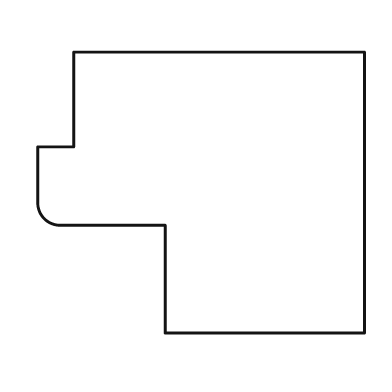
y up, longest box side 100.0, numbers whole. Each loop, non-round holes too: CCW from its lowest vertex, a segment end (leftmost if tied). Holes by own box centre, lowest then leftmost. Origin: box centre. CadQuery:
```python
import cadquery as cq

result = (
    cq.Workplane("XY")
    .moveTo(-11.0, -43.0)
    .lineTo(50.0, -43.0)
    .lineTo(50.0, 43.0)
    .lineTo(-39.0, 43.0)
    .lineTo(-39.0, 14.0)
    .lineTo(-50.0, 14.0)
    .lineTo(-50.0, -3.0)
    .threePointArc((-48.0, -8.0), (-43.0, -10.0))
    .lineTo(-11.0, -10.0)
    .close()
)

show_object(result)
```